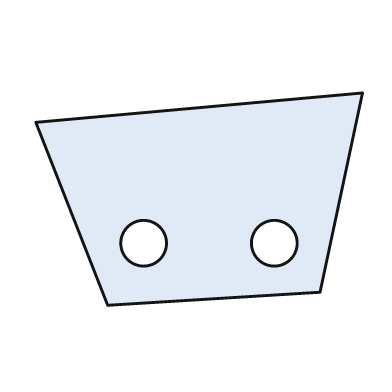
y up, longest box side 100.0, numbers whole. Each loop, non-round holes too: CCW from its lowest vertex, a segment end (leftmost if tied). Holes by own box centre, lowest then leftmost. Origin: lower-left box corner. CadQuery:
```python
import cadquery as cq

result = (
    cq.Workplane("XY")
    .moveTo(22.0, 0.0)
    .lineTo(87.0, 4.0)
    .lineTo(100.0, 65.0)
    .lineTo(0.0, 56.0)
    .close()
    .moveTo(33.0, 19.0)
    .circle(7.0)
    .moveTo(73.0, 19.0)
    .circle(7.0)
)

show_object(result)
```